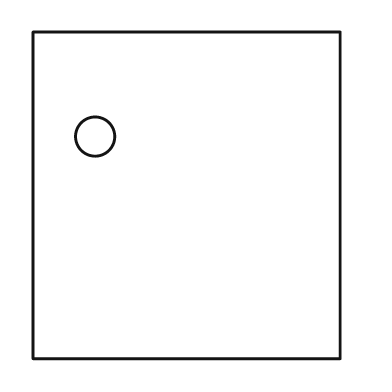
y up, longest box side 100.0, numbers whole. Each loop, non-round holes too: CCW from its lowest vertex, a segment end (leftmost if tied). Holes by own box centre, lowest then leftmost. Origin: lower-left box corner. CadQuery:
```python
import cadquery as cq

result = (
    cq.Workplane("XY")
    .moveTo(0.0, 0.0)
    .lineTo(94.0, 0.0)
    .lineTo(94.0, 100.0)
    .lineTo(0.0, 100.0)
    .close()
    .moveTo(19.0, 68.0)
    .circle(6.0)
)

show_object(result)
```